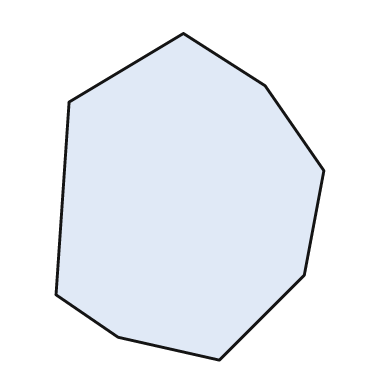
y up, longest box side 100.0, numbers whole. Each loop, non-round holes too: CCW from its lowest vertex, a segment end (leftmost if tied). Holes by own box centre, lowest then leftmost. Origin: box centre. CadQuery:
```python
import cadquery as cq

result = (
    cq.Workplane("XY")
    .moveTo(9.0, -50.0)
    .lineTo(35.0, -24.0)
    .lineTo(41.0, 8.0)
    .lineTo(23.0, 34.0)
    .lineTo(-2.0, 50.0)
    .lineTo(-37.0, 29.0)
    .lineTo(-41.0, -30.0)
    .lineTo(-22.0, -43.0)
    .close()
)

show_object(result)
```